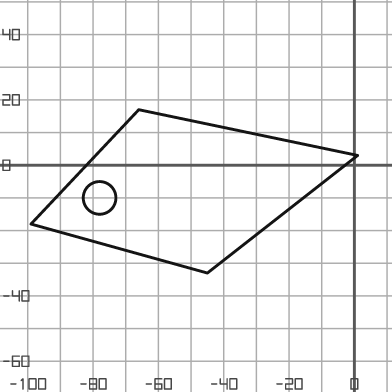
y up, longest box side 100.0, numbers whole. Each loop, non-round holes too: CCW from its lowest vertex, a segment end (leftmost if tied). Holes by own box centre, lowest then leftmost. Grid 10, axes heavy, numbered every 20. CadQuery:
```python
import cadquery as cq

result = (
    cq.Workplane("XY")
    .moveTo(-45.0, -33.0)
    .lineTo(1.0, 3.0)
    .lineTo(-66.0, 17.0)
    .lineTo(-99.0, -18.0)
    .close()
    .moveTo(-78.0, -10.0)
    .circle(5.0)
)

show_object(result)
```